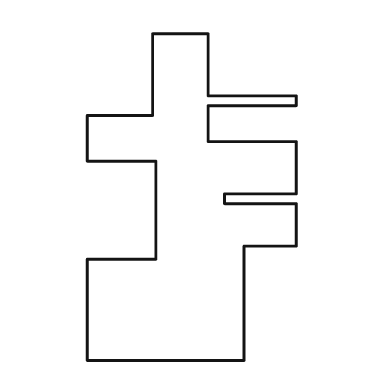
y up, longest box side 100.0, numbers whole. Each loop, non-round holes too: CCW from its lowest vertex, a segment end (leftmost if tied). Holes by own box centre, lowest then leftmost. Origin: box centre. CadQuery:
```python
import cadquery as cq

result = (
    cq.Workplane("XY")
    .moveTo(-32.0, -50.0)
    .lineTo(16.0, -50.0)
    .lineTo(16.0, -15.0)
    .lineTo(32.0, -15.0)
    .lineTo(32.0, -2.0)
    .lineTo(10.0, -2.0)
    .lineTo(10.0, 1.0)
    .lineTo(32.0, 1.0)
    .lineTo(32.0, 17.0)
    .lineTo(5.0, 17.0)
    .lineTo(5.0, 28.0)
    .lineTo(32.0, 28.0)
    .lineTo(32.0, 31.0)
    .lineTo(5.0, 31.0)
    .lineTo(5.0, 50.0)
    .lineTo(-12.0, 50.0)
    .lineTo(-12.0, 25.0)
    .lineTo(-32.0, 25.0)
    .lineTo(-32.0, 11.0)
    .lineTo(-11.0, 11.0)
    .lineTo(-11.0, -19.0)
    .lineTo(-32.0, -19.0)
    .close()
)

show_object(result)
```